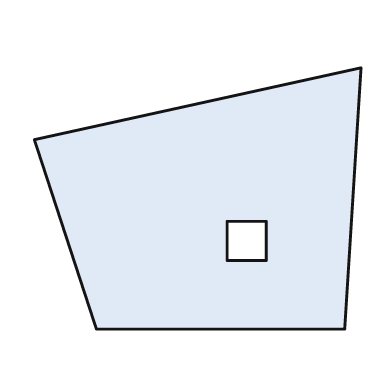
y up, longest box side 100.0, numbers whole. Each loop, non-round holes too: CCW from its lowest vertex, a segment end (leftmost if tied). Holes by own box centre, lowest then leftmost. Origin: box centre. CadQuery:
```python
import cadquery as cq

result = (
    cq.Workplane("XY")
    .moveTo(-31.0, -40.0)
    .lineTo(45.0, -40.0)
    .lineTo(50.0, 40.0)
    .lineTo(-50.0, 18.0)
    .close()
    .moveTo(9.0, -19.0)
    .lineTo(21.0, -19.0)
    .lineTo(21.0, -7.0)
    .lineTo(9.0, -7.0)
    .close()
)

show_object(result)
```